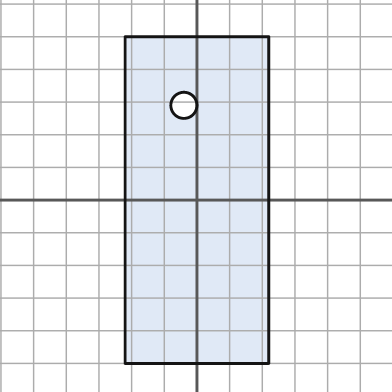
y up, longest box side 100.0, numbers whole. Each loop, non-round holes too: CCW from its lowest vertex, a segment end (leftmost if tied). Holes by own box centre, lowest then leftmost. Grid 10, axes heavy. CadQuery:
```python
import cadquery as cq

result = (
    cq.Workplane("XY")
    .moveTo(-22.0, -50.0)
    .lineTo(22.0, -50.0)
    .lineTo(22.0, 50.0)
    .lineTo(-22.0, 50.0)
    .close()
    .moveTo(-4.0, 29.0)
    .circle(4.0)
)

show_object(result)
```